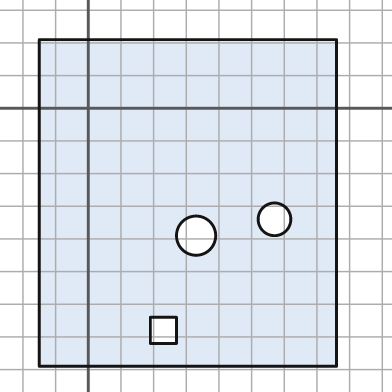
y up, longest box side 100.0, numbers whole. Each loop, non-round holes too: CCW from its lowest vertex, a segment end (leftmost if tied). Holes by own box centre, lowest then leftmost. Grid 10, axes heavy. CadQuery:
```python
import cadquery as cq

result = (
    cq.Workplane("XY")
    .moveTo(-15.0, -79.0)
    .lineTo(76.0, -79.0)
    .lineTo(76.0, 21.0)
    .lineTo(-15.0, 21.0)
    .close()
    .moveTo(19.0, -72.0)
    .lineTo(27.0, -72.0)
    .lineTo(27.0, -64.0)
    .lineTo(19.0, -64.0)
    .close()
    .moveTo(33.0, -39.0)
    .circle(6.0)
    .moveTo(57.0, -34.0)
    .circle(5.0)
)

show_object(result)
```